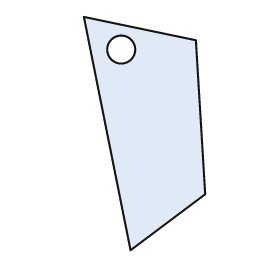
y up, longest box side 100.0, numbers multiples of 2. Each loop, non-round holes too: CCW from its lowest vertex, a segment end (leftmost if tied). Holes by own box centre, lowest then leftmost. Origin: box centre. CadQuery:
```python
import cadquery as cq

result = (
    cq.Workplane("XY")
    .moveTo(-6.0, -50.0)
    .lineTo(26.0, -26.0)
    .lineTo(22.0, 40.0)
    .lineTo(-26.0, 50.0)
    .close()
    .moveTo(-10.0, 36.0)
    .circle(6.0)
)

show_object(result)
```